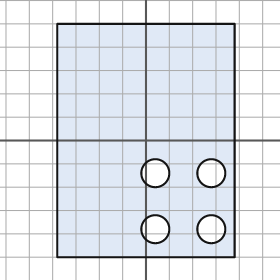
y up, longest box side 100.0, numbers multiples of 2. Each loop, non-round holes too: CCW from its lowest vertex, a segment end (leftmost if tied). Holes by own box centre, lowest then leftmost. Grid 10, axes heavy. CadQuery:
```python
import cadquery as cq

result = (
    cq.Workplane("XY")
    .moveTo(-38.0, -50.0)
    .lineTo(38.0, -50.0)
    .lineTo(38.0, 50.0)
    .lineTo(-38.0, 50.0)
    .close()
    .moveTo(4.0, -38.0)
    .circle(6.0)
    .moveTo(28.0, -38.0)
    .circle(6.0)
    .moveTo(4.0, -14.0)
    .circle(6.0)
    .moveTo(28.0, -14.0)
    .circle(6.0)
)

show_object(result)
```